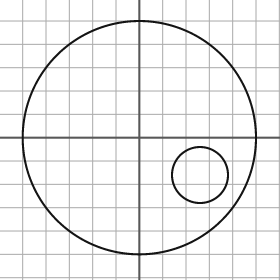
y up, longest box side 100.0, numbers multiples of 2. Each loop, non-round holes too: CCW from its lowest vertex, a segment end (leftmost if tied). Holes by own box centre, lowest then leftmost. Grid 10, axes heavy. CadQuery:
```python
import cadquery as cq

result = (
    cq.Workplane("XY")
    .moveTo(0.0, 0.0)
    .circle(50.0)
    .moveTo(26.0, -16.0)
    .circle(12.0)
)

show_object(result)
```